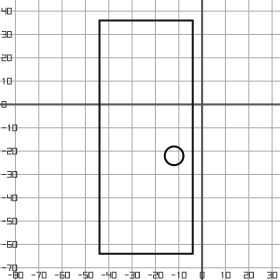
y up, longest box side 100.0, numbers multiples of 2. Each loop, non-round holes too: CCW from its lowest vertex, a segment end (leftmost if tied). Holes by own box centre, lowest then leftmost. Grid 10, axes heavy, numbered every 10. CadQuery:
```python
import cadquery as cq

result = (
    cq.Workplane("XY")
    .moveTo(-44.0, -64.0)
    .lineTo(-4.0, -64.0)
    .lineTo(-4.0, 36.0)
    .lineTo(-44.0, 36.0)
    .close()
    .moveTo(-12.0, -22.0)
    .circle(4.0)
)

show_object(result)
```